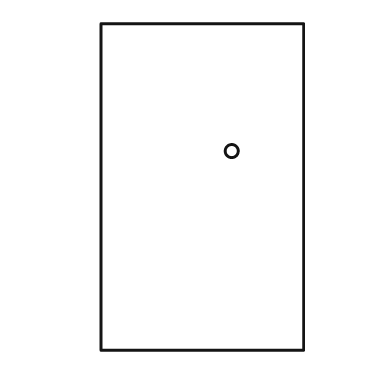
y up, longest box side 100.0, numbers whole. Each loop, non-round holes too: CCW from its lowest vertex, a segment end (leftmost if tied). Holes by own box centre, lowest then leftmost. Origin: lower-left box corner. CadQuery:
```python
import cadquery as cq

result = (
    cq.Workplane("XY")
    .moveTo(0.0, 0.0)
    .lineTo(62.0, 0.0)
    .lineTo(62.0, 100.0)
    .lineTo(0.0, 100.0)
    .close()
    .moveTo(40.0, 61.0)
    .circle(2.0)
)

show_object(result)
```